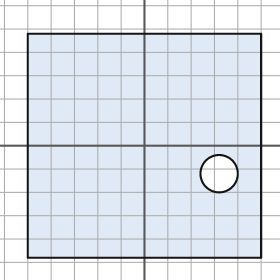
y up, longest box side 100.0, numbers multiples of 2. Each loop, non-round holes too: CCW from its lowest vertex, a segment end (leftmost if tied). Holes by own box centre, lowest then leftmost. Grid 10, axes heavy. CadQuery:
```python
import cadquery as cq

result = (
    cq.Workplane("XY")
    .moveTo(-50.0, -48.0)
    .lineTo(50.0, -48.0)
    .lineTo(50.0, 48.0)
    .lineTo(-50.0, 48.0)
    .close()
    .moveTo(32.0, -12.0)
    .circle(8.0)
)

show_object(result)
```